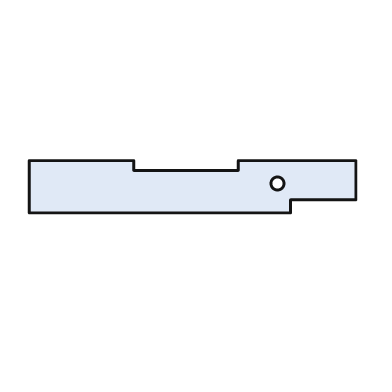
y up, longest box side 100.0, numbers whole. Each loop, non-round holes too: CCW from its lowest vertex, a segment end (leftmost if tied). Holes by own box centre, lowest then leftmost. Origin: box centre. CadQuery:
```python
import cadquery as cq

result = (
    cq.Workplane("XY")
    .moveTo(-50.0, -8.0)
    .lineTo(30.0, -8.0)
    .lineTo(30.0, -4.0)
    .lineTo(50.0, -4.0)
    .lineTo(50.0, 8.0)
    .lineTo(14.0, 8.0)
    .lineTo(14.0, 5.0)
    .lineTo(-18.0, 5.0)
    .lineTo(-18.0, 8.0)
    .lineTo(-50.0, 8.0)
    .close()
    .moveTo(26.0, 1.0)
    .circle(2.0)
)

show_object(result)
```